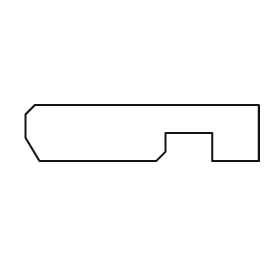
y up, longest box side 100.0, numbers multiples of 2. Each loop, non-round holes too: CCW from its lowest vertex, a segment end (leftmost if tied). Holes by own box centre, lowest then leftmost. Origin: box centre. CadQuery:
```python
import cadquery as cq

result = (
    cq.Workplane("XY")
    .moveTo(-44.0, -12.0)
    .lineTo(6.0, -12.0)
    .lineTo(10.0, -8.0)
    .lineTo(10.0, 0.0)
    .lineTo(30.0, 0.0)
    .lineTo(30.0, -12.0)
    .lineTo(50.0, -12.0)
    .lineTo(50.0, 12.0)
    .lineTo(-46.0, 12.0)
    .lineTo(-50.0, 8.0)
    .lineTo(-50.0, -2.0)
    .close()
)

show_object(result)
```